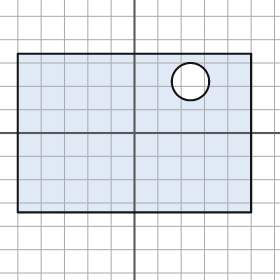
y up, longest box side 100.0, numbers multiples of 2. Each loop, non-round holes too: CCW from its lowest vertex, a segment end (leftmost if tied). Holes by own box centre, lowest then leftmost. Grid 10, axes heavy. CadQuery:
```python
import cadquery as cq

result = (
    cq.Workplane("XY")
    .moveTo(-50.0, -34.0)
    .lineTo(50.0, -34.0)
    .lineTo(50.0, 34.0)
    .lineTo(-50.0, 34.0)
    .close()
    .moveTo(24.0, 22.0)
    .circle(8.0)
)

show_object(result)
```